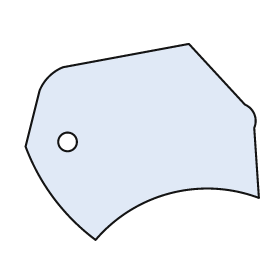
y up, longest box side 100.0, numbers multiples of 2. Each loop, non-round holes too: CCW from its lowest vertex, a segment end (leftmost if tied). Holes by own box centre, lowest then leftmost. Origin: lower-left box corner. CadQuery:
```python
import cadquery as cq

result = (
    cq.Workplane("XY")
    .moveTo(30.0, 0.0)
    .threePointArc((62.0, 20.0), (100.0, 18.0))
    .lineTo(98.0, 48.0)
    .threePointArc((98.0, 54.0), (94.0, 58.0))
    .lineTo(70.0, 84.0)
    .lineTo(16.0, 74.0)
    .threePointArc((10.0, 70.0), (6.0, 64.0))
    .lineTo(0.0, 40.0)
    .threePointArc((12.0, 18.0), (30.0, 0.0))
    .close()
    .moveTo(18.0, 42.0)
    .circle(4.0)
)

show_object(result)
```